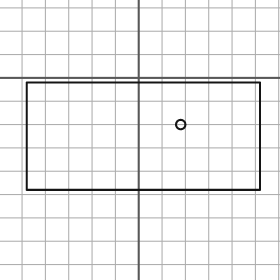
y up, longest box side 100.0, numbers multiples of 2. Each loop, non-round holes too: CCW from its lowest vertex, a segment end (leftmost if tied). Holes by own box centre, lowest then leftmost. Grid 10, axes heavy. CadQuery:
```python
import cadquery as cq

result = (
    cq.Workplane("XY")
    .moveTo(-48.0, -48.0)
    .lineTo(52.0, -48.0)
    .lineTo(52.0, -2.0)
    .lineTo(-48.0, -2.0)
    .close()
    .moveTo(18.0, -20.0)
    .circle(2.0)
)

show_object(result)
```